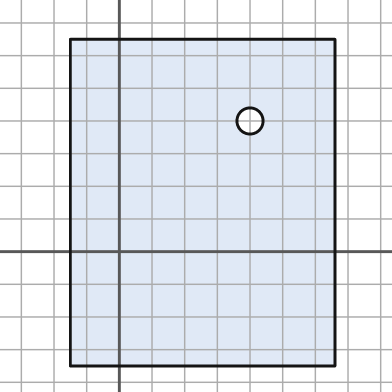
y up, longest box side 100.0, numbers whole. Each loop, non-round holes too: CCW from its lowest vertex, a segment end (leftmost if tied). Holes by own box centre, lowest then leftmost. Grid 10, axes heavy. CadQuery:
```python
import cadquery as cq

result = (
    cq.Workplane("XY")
    .moveTo(-15.0, -35.0)
    .lineTo(66.0, -35.0)
    .lineTo(66.0, 65.0)
    .lineTo(-15.0, 65.0)
    .close()
    .moveTo(40.0, 40.0)
    .circle(4.0)
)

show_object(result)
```